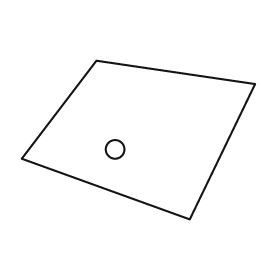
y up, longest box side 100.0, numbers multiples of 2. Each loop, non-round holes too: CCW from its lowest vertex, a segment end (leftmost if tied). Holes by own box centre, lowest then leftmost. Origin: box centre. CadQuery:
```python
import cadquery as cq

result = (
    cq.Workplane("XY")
    .moveTo(22.0, -34.0)
    .lineTo(50.0, 24.0)
    .lineTo(-18.0, 34.0)
    .lineTo(-50.0, -8.0)
    .close()
    .moveTo(-10.0, -4.0)
    .circle(4.0)
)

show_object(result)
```